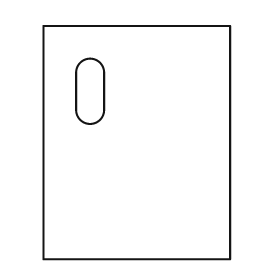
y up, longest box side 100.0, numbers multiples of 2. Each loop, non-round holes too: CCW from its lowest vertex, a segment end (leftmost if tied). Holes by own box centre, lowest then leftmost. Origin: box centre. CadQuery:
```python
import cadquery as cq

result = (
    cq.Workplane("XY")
    .moveTo(-40.0, -50.0)
    .lineTo(40.0, -50.0)
    .lineTo(40.0, 50.0)
    .lineTo(-40.0, 50.0)
    .close()
    .moveTo(-26.0, 14.0)
    .threePointArc((-20.0, 8.0), (-14.0, 14.0))
    .lineTo(-14.0, 30.0)
    .threePointArc((-20.0, 36.0), (-26.0, 30.0))
    .close()
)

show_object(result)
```